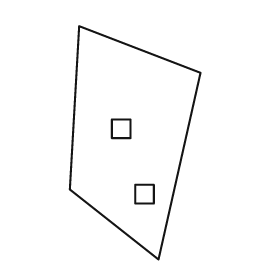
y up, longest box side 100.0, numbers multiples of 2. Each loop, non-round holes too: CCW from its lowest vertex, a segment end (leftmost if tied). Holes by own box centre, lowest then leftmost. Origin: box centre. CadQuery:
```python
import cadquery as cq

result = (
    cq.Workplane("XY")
    .moveTo(10.0, -50.0)
    .lineTo(28.0, 30.0)
    .lineTo(-24.0, 50.0)
    .lineTo(-28.0, -20.0)
    .close()
    .moveTo(0.0, -26.0)
    .lineTo(8.0, -26.0)
    .lineTo(8.0, -18.0)
    .lineTo(0.0, -18.0)
    .close()
    .moveTo(-10.0, 2.0)
    .lineTo(-2.0, 2.0)
    .lineTo(-2.0, 10.0)
    .lineTo(-10.0, 10.0)
    .close()
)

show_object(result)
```